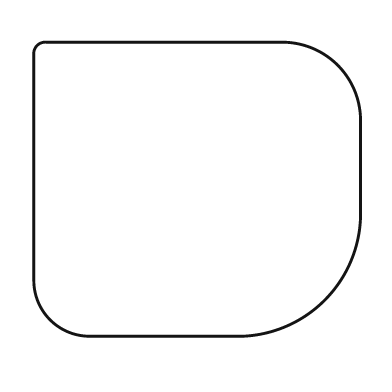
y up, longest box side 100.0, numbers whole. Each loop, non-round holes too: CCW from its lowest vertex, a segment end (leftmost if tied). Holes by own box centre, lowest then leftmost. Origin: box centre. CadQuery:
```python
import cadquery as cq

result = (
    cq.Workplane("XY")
    .moveTo(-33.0, -45.0)
    .lineTo(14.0, -45.0)
    .threePointArc((39.0, -34.0), (50.0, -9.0))
    .lineTo(50.0, 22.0)
    .threePointArc((43.0, 38.0), (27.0, 45.0))
    .lineTo(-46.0, 45.0)
    .threePointArc((-49.0, 44.0), (-50.0, 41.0))
    .lineTo(-50.0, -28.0)
    .threePointArc((-45.0, -40.0), (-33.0, -45.0))
    .close()
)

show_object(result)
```